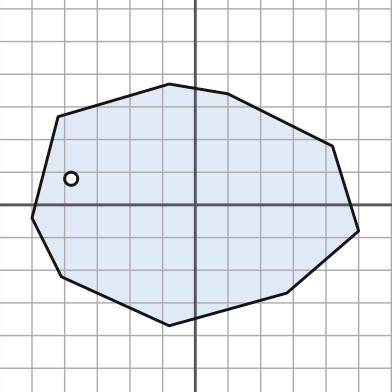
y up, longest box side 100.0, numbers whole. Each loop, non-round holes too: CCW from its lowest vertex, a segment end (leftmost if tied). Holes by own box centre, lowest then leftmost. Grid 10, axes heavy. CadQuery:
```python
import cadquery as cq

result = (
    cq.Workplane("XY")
    .moveTo(-8.0, -37.0)
    .lineTo(28.0, -27.0)
    .lineTo(50.0, -8.0)
    .lineTo(42.0, 18.0)
    .lineTo(10.0, 34.0)
    .lineTo(-8.0, 37.0)
    .lineTo(-42.0, 27.0)
    .lineTo(-50.0, -4.0)
    .lineTo(-41.0, -22.0)
    .close()
    .moveTo(-38.0, 8.0)
    .circle(2.0)
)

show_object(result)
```